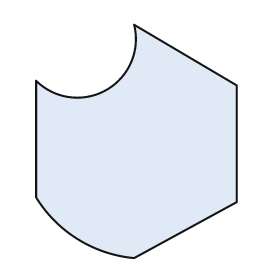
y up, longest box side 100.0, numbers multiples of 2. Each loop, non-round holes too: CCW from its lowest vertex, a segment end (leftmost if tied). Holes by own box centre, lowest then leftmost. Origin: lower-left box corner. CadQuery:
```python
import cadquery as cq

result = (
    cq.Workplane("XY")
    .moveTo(42.0, 0.0)
    .lineTo(86.0, 24.0)
    .lineTo(86.0, 74.0)
    .lineTo(42.0, 100.0)
    .threePointArc((30.0, 72.0), (0.0, 76.0))
    .lineTo(0.0, 26.0)
    .threePointArc((18.0, 8.0), (42.0, 0.0))
    .close()
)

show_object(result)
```